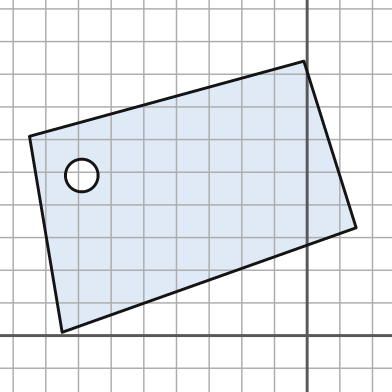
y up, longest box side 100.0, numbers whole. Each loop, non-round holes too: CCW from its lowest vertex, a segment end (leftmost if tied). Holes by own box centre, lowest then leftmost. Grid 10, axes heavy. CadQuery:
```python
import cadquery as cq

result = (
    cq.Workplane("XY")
    .moveTo(-75.0, 1.0)
    .lineTo(15.0, 33.0)
    .lineTo(-1.0, 84.0)
    .lineTo(-85.0, 61.0)
    .close()
    .moveTo(-69.0, 49.0)
    .circle(5.0)
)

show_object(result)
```